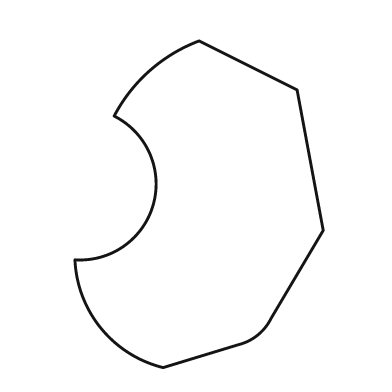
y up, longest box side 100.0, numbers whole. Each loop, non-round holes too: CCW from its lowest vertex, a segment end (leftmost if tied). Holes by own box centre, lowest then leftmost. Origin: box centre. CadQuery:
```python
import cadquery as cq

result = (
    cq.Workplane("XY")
    .moveTo(-11.0, -50.0)
    .lineTo(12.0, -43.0)
    .threePointArc((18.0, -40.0), (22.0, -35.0))
    .lineTo(38.0, -8.0)
    .lineTo(30.0, 35.0)
    .lineTo(0.0, 50.0)
    .threePointArc((-15.0, 41.0), (-26.0, 27.0))
    .threePointArc((-14.0, 0.0), (-38.0, -17.0))
    .threePointArc((-30.0, -38.0), (-11.0, -50.0))
    .close()
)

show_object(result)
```